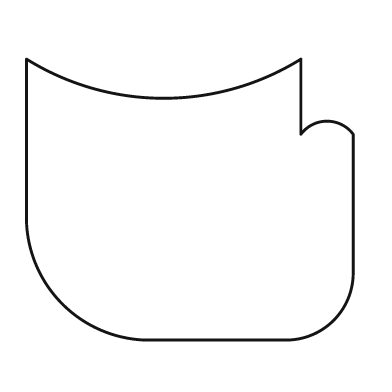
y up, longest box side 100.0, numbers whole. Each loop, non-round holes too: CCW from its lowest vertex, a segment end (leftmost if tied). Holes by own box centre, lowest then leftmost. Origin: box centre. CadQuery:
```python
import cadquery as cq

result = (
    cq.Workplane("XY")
    .moveTo(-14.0, -43.0)
    .lineTo(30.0, -43.0)
    .threePointArc((44.0, -37.0), (50.0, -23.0))
    .lineTo(50.0, 20.0)
    .threePointArc((42.0, 24.0), (34.0, 20.0))
    .lineTo(34.0, 43.0)
    .threePointArc((-8.0, 31.0), (-50.0, 43.0))
    .lineTo(-50.0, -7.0)
    .threePointArc((-39.0, -32.0), (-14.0, -43.0))
    .close()
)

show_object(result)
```